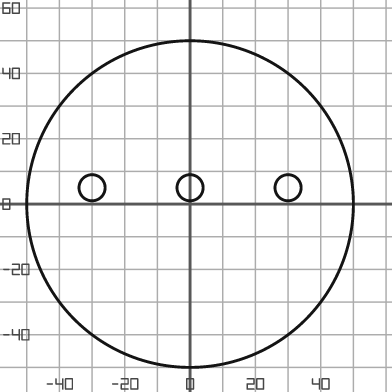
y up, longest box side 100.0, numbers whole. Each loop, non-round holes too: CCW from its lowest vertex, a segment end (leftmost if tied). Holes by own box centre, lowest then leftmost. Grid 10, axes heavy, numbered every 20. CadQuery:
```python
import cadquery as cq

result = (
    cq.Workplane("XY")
    .moveTo(0.0, 0.0)
    .circle(50.0)
    .moveTo(-30.0, 5.0)
    .circle(4.0)
    .moveTo(0.0, 5.0)
    .circle(4.0)
    .moveTo(30.0, 5.0)
    .circle(4.0)
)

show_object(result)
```